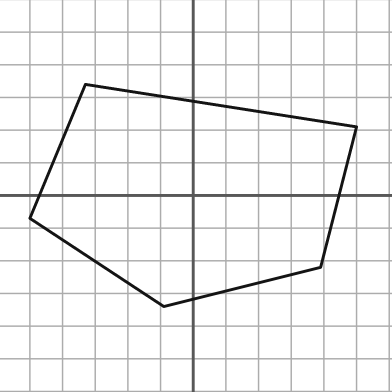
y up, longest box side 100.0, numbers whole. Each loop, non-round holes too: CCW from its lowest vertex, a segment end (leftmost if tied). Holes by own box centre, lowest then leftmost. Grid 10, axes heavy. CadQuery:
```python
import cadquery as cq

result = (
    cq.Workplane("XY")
    .moveTo(-9.0, -34.0)
    .lineTo(39.0, -22.0)
    .lineTo(50.0, 21.0)
    .lineTo(-33.0, 34.0)
    .lineTo(-50.0, -7.0)
    .close()
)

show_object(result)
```